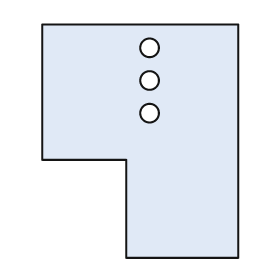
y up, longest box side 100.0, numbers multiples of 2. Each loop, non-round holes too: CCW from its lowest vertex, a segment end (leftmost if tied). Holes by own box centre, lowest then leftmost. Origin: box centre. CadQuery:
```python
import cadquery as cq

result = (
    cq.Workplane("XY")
    .moveTo(-6.0, -50.0)
    .lineTo(42.0, -50.0)
    .lineTo(42.0, 50.0)
    .lineTo(-42.0, 50.0)
    .lineTo(-42.0, -8.0)
    .lineTo(-6.0, -8.0)
    .close()
    .moveTo(4.0, 12.0)
    .circle(4.0)
    .moveTo(4.0, 26.0)
    .circle(4.0)
    .moveTo(4.0, 40.0)
    .circle(4.0)
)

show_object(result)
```